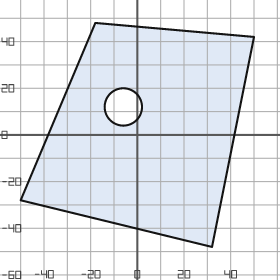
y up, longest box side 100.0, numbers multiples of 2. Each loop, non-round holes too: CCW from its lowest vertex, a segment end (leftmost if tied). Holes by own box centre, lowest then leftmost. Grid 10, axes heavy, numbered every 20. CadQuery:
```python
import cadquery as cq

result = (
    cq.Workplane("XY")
    .moveTo(32.0, -48.0)
    .lineTo(50.0, 42.0)
    .lineTo(-18.0, 48.0)
    .lineTo(-50.0, -28.0)
    .close()
    .moveTo(-6.0, 12.0)
    .circle(8.0)
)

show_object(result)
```